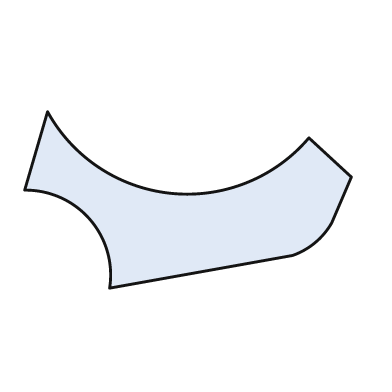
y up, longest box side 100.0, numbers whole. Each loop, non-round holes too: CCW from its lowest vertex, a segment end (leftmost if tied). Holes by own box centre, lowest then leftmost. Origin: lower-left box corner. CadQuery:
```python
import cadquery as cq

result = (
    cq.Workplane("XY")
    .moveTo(26.0, 0.0)
    .lineTo(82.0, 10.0)
    .threePointArc((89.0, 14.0), (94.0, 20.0))
    .lineTo(100.0, 34.0)
    .lineTo(87.0, 46.0)
    .threePointArc((45.0, 29.0), (7.0, 54.0))
    .lineTo(0.0, 30.0)
    .threePointArc((20.0, 21.0), (26.0, 0.0))
    .close()
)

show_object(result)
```